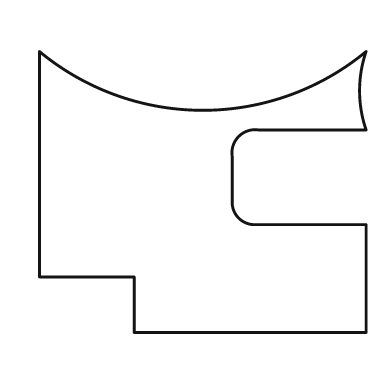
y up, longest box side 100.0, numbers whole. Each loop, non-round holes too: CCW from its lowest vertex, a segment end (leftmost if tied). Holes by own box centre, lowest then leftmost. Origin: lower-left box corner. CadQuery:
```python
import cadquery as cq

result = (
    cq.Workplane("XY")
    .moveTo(29.0, 0.0)
    .lineTo(100.0, 0.0)
    .lineTo(100.0, 33.0)
    .lineTo(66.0, 33.0)
    .threePointArc((61.0, 35.0), (59.0, 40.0))
    .lineTo(59.0, 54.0)
    .threePointArc((61.0, 60.0), (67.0, 62.0))
    .lineTo(100.0, 62.0)
    .threePointArc((98.0, 74.0), (100.0, 86.0))
    .threePointArc((50.0, 68.0), (0.0, 86.0))
    .lineTo(0.0, 17.0)
    .lineTo(29.0, 17.0)
    .close()
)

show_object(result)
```